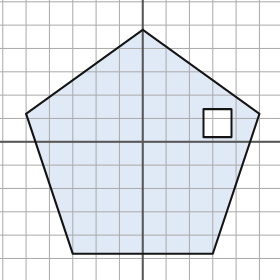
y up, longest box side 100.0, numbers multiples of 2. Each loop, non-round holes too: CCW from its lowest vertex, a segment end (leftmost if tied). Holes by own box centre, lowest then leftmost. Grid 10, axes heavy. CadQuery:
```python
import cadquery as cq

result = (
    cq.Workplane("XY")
    .moveTo(-30.0, -48.0)
    .lineTo(30.0, -48.0)
    .lineTo(50.0, 12.0)
    .lineTo(0.0, 48.0)
    .lineTo(-50.0, 12.0)
    .close()
    .moveTo(26.0, 2.0)
    .lineTo(38.0, 2.0)
    .lineTo(38.0, 14.0)
    .lineTo(26.0, 14.0)
    .close()
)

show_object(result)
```